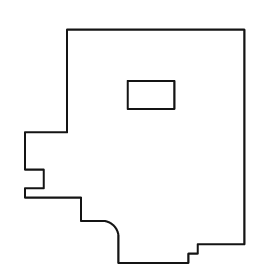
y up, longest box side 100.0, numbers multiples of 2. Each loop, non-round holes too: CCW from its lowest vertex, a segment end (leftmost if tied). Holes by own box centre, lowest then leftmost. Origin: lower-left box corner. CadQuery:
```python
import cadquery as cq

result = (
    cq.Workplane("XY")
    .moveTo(40.0, 0.0)
    .lineTo(70.0, 0.0)
    .lineTo(70.0, 4.0)
    .lineTo(74.0, 4.0)
    .lineTo(74.0, 8.0)
    .lineTo(94.0, 8.0)
    .lineTo(94.0, 100.0)
    .lineTo(18.0, 100.0)
    .lineTo(18.0, 56.0)
    .lineTo(0.0, 56.0)
    .lineTo(0.0, 40.0)
    .lineTo(8.0, 40.0)
    .lineTo(8.0, 32.0)
    .lineTo(0.0, 32.0)
    .lineTo(0.0, 28.0)
    .lineTo(24.0, 28.0)
    .lineTo(24.0, 18.0)
    .lineTo(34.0, 18.0)
    .threePointArc((38.0, 16.0), (40.0, 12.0))
    .close()
    .moveTo(44.0, 66.0)
    .lineTo(64.0, 66.0)
    .lineTo(64.0, 78.0)
    .lineTo(44.0, 78.0)
    .close()
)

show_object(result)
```